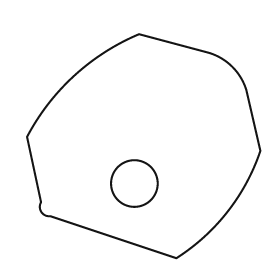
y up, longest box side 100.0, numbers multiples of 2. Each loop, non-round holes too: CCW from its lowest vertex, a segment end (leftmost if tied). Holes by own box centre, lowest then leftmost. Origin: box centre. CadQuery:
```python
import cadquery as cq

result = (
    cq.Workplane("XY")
    .moveTo(14.0, -48.0)
    .threePointArc((36.0, -28.0), (50.0, -2.0))
    .lineTo(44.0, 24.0)
    .threePointArc((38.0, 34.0), (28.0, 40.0))
    .lineTo(-2.0, 48.0)
    .threePointArc((-30.0, 30.0), (-50.0, 4.0))
    .lineTo(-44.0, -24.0)
    .threePointArc((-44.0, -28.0), (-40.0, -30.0))
    .close()
    .moveTo(-4.0, -16.0)
    .circle(10.0)
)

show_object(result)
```